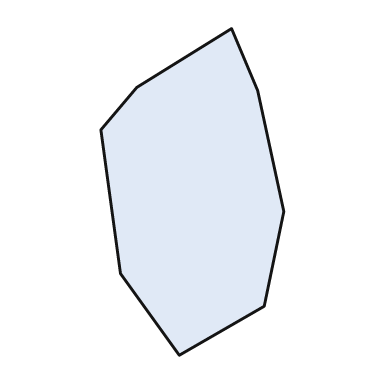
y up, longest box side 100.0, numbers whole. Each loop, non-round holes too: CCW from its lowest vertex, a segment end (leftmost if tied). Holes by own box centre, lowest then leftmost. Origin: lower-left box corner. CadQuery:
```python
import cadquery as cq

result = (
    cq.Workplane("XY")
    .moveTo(24.0, 0.0)
    .lineTo(50.0, 15.0)
    .lineTo(56.0, 44.0)
    .lineTo(48.0, 81.0)
    .lineTo(40.0, 100.0)
    .lineTo(11.0, 82.0)
    .lineTo(0.0, 69.0)
    .lineTo(6.0, 25.0)
    .close()
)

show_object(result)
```